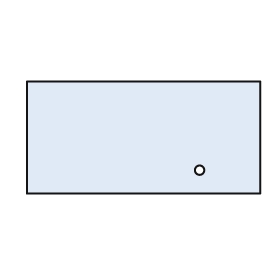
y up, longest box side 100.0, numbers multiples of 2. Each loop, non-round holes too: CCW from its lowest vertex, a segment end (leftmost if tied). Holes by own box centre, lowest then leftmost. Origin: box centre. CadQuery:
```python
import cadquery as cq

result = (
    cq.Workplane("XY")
    .moveTo(-50.0, -24.0)
    .lineTo(50.0, -24.0)
    .lineTo(50.0, 24.0)
    .lineTo(-50.0, 24.0)
    .close()
    .moveTo(24.0, -14.0)
    .circle(2.0)
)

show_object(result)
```